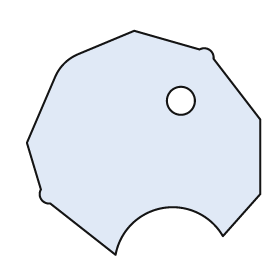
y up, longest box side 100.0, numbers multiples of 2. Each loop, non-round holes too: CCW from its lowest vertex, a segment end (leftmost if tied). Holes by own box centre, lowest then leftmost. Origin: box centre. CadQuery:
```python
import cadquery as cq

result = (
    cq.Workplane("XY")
    .moveTo(-12.0, -48.0)
    .threePointArc((8.0, -28.0), (34.0, -40.0))
    .lineTo(50.0, -22.0)
    .lineTo(50.0, 10.0)
    .lineTo(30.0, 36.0)
    .threePointArc((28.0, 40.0), (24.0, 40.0))
    .lineTo(-4.0, 48.0)
    .lineTo(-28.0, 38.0)
    .threePointArc((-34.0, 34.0), (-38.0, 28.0))
    .lineTo(-50.0, 0.0)
    .lineTo(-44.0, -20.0)
    .threePointArc((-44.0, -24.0), (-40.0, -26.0))
    .close()
    .moveTo(16.0, 18.0)
    .circle(6.0)
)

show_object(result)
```